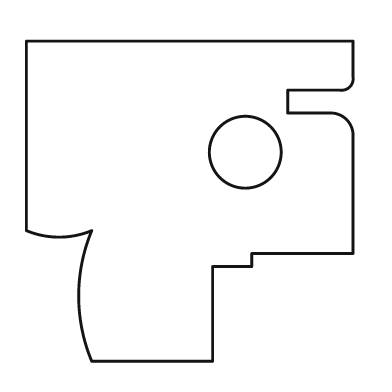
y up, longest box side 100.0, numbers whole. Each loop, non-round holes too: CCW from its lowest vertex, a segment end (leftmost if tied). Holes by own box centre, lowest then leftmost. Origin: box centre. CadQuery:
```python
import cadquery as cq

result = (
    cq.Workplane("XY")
    .moveTo(-30.0, -49.0)
    .lineTo(7.0, -49.0)
    .lineTo(7.0, -20.0)
    .lineTo(19.0, -20.0)
    .lineTo(19.0, -16.0)
    .lineTo(50.0, -16.0)
    .lineTo(50.0, 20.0)
    .threePointArc((48.0, 25.0), (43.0, 27.0))
    .lineTo(30.0, 27.0)
    .lineTo(30.0, 34.0)
    .lineTo(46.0, 34.0)
    .threePointArc((49.0, 35.0), (50.0, 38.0))
    .lineTo(50.0, 49.0)
    .lineTo(-50.0, 49.0)
    .lineTo(-50.0, -9.0)
    .threePointArc((-40.0, -11.0), (-30.0, -9.0))
    .threePointArc((-34.0, -29.0), (-30.0, -49.0))
    .close()
    .moveTo(17.0, 15.0)
    .circle(11.0)
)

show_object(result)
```